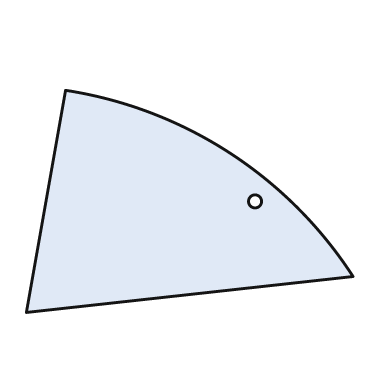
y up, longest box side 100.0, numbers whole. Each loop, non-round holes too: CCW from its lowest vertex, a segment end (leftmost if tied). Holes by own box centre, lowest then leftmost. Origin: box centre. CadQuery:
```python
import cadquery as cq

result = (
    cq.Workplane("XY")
    .moveTo(-50.0, -34.0)
    .lineTo(50.0, -23.0)
    .threePointArc((12.0, 15.0), (-38.0, 34.0))
    .close()
    .moveTo(20.0, 0.0)
    .circle(2.0)
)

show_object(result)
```